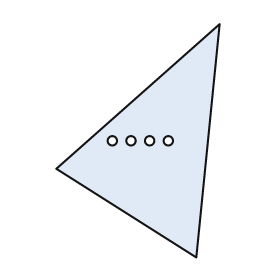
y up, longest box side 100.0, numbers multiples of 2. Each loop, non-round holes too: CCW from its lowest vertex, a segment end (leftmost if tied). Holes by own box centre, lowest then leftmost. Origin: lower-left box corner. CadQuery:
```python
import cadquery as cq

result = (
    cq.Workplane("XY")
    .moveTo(60.0, 0.0)
    .lineTo(70.0, 100.0)
    .lineTo(0.0, 38.0)
    .close()
    .moveTo(24.0, 50.0)
    .circle(2.0)
    .moveTo(32.0, 50.0)
    .circle(2.0)
    .moveTo(40.0, 50.0)
    .circle(2.0)
    .moveTo(48.0, 50.0)
    .circle(2.0)
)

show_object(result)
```